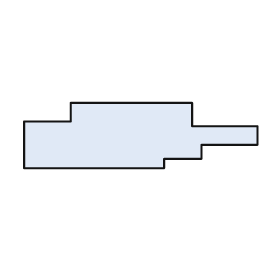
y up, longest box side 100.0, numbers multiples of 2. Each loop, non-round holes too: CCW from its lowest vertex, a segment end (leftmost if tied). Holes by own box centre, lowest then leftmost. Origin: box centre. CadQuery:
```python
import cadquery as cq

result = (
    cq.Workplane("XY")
    .moveTo(-50.0, -14.0)
    .lineTo(10.0, -14.0)
    .lineTo(10.0, -10.0)
    .lineTo(26.0, -10.0)
    .lineTo(26.0, -4.0)
    .lineTo(50.0, -4.0)
    .lineTo(50.0, 4.0)
    .lineTo(22.0, 4.0)
    .lineTo(22.0, 14.0)
    .lineTo(-30.0, 14.0)
    .lineTo(-30.0, 6.0)
    .lineTo(-50.0, 6.0)
    .close()
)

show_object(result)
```